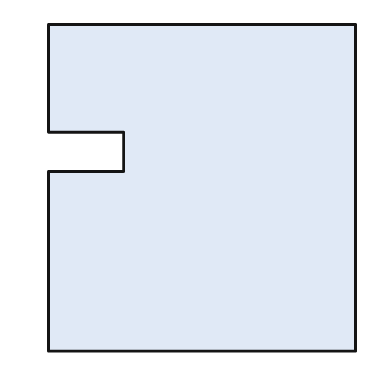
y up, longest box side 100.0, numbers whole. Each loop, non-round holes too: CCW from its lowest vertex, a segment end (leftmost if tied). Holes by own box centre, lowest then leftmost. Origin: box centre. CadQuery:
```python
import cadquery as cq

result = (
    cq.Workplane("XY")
    .moveTo(-47.0, -50.0)
    .lineTo(47.0, -50.0)
    .lineTo(47.0, 50.0)
    .lineTo(-47.0, 50.0)
    .lineTo(-47.0, 17.0)
    .lineTo(-24.0, 17.0)
    .lineTo(-24.0, 5.0)
    .lineTo(-47.0, 5.0)
    .close()
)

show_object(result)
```